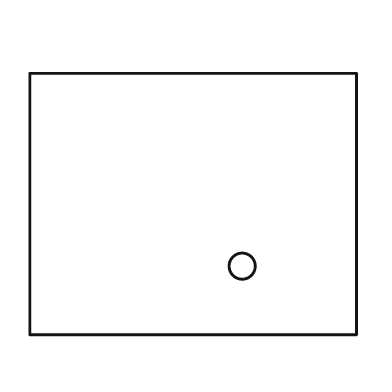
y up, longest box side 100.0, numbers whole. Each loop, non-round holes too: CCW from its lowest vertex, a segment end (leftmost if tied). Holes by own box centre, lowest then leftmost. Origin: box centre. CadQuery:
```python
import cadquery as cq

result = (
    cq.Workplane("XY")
    .moveTo(-50.0, -40.0)
    .lineTo(50.0, -40.0)
    .lineTo(50.0, 40.0)
    .lineTo(-50.0, 40.0)
    .close()
    .moveTo(15.0, -19.0)
    .circle(4.0)
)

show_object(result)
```